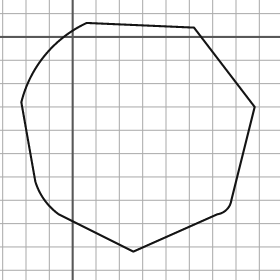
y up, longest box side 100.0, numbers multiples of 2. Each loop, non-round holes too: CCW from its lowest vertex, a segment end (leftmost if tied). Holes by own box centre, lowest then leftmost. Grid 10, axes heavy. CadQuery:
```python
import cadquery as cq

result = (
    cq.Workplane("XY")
    .moveTo(26.0, -92.0)
    .lineTo(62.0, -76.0)
    .threePointArc((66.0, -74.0), (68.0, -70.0))
    .lineTo(78.0, -30.0)
    .lineTo(52.0, 4.0)
    .lineTo(6.0, 6.0)
    .threePointArc((-12.0, -8.0), (-22.0, -28.0))
    .lineTo(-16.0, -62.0)
    .threePointArc((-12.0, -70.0), (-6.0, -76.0))
    .close()
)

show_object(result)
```